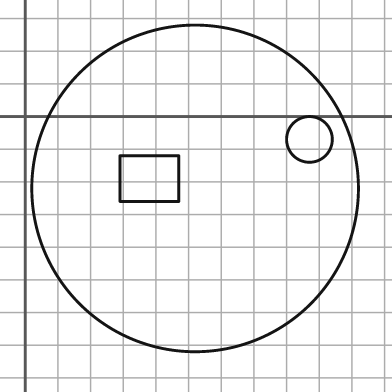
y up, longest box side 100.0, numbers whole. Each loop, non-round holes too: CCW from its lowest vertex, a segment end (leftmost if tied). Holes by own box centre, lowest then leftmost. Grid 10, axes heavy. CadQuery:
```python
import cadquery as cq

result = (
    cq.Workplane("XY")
    .moveTo(52.0, -22.0)
    .circle(50.0)
    .moveTo(29.0, -26.0)
    .lineTo(47.0, -26.0)
    .lineTo(47.0, -12.0)
    .lineTo(29.0, -12.0)
    .close()
    .moveTo(87.0, -7.0)
    .circle(7.0)
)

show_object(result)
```